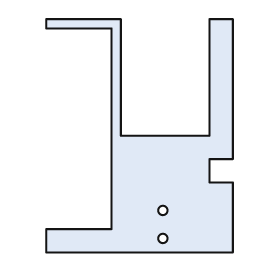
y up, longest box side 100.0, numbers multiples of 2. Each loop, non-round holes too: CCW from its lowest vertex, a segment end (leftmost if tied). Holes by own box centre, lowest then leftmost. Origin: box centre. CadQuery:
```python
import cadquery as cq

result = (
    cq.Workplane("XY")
    .moveTo(-40.0, -50.0)
    .lineTo(40.0, -50.0)
    .lineTo(40.0, -20.0)
    .lineTo(30.0, -20.0)
    .lineTo(30.0, -10.0)
    .lineTo(40.0, -10.0)
    .lineTo(40.0, 50.0)
    .lineTo(30.0, 50.0)
    .lineTo(30.0, 0.0)
    .lineTo(-8.0, 0.0)
    .lineTo(-8.0, 50.0)
    .lineTo(-40.0, 50.0)
    .lineTo(-40.0, 46.0)
    .lineTo(-12.0, 46.0)
    .lineTo(-12.0, -40.0)
    .lineTo(-40.0, -40.0)
    .close()
    .moveTo(10.0, -44.0)
    .circle(2.0)
    .moveTo(10.0, -32.0)
    .circle(2.0)
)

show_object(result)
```